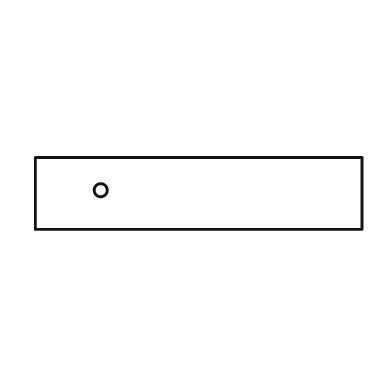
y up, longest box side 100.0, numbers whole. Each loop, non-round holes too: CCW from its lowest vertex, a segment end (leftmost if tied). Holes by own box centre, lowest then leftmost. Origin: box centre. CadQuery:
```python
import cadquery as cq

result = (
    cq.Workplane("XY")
    .moveTo(-50.0, -11.0)
    .lineTo(50.0, -11.0)
    .lineTo(50.0, 11.0)
    .lineTo(-50.0, 11.0)
    .close()
    .moveTo(-30.0, 1.0)
    .circle(2.0)
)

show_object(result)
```